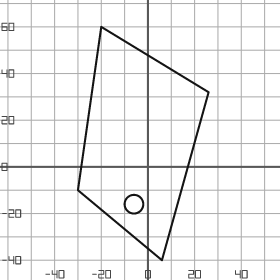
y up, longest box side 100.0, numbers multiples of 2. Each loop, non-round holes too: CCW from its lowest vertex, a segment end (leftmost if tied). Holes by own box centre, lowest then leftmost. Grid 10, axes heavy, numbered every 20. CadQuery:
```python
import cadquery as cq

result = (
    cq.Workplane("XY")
    .moveTo(6.0, -40.0)
    .lineTo(26.0, 32.0)
    .lineTo(-20.0, 60.0)
    .lineTo(-30.0, -10.0)
    .close()
    .moveTo(-6.0, -16.0)
    .circle(4.0)
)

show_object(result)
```